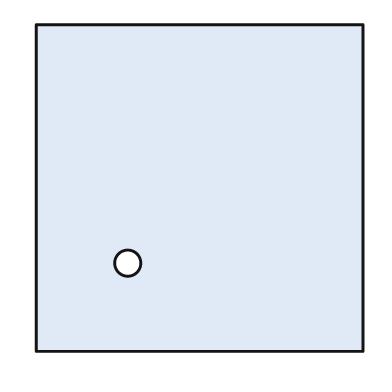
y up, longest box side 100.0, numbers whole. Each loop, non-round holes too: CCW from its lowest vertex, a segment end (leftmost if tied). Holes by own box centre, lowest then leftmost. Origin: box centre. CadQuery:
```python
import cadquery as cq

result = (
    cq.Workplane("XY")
    .moveTo(-50.0, -50.0)
    .lineTo(50.0, -50.0)
    .lineTo(50.0, 50.0)
    .lineTo(-50.0, 50.0)
    .close()
    .moveTo(-22.0, -23.0)
    .circle(4.0)
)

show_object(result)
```